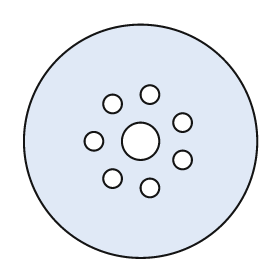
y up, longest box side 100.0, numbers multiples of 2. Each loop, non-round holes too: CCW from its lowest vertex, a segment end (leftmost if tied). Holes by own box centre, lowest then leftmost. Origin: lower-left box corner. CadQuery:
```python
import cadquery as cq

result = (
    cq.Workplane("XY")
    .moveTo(50.0, 50.0)
    .circle(50.0)
    .moveTo(54.0, 30.0)
    .circle(4.0)
    .moveTo(38.0, 34.0)
    .circle(4.0)
    .moveTo(68.0, 42.0)
    .circle(4.0)
    .moveTo(30.0, 50.0)
    .circle(4.0)
    .moveTo(50.0, 50.0)
    .circle(8.0)
    .moveTo(68.0, 58.0)
    .circle(4.0)
    .moveTo(38.0, 66.0)
    .circle(4.0)
    .moveTo(54.0, 70.0)
    .circle(4.0)
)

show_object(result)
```